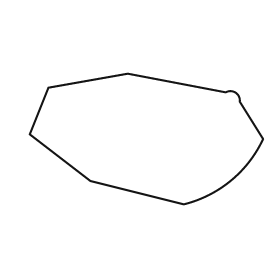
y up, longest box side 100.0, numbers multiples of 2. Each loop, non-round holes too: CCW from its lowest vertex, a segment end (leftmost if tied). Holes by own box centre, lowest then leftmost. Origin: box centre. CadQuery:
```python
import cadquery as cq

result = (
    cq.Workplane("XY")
    .moveTo(16.0, -28.0)
    .threePointArc((36.0, -18.0), (50.0, 0.0))
    .lineTo(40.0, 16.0)
    .threePointArc((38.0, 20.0), (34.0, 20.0))
    .lineTo(-8.0, 28.0)
    .lineTo(-42.0, 22.0)
    .lineTo(-50.0, 2.0)
    .lineTo(-24.0, -18.0)
    .close()
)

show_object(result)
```